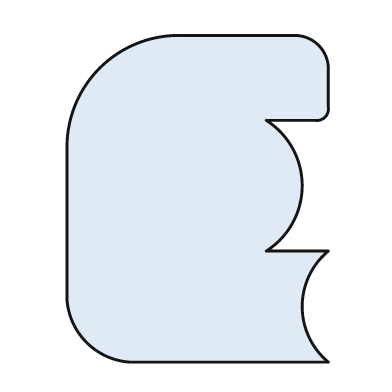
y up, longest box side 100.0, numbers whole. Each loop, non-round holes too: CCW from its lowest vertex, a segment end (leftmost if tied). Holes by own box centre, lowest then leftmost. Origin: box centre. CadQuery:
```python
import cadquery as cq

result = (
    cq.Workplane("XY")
    .moveTo(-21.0, -50.0)
    .lineTo(40.0, -50.0)
    .threePointArc((32.0, -33.0), (40.0, -16.0))
    .lineTo(21.0, -16.0)
    .threePointArc((32.0, 4.0), (21.0, 24.0))
    .lineTo(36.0, 24.0)
    .threePointArc((39.0, 25.0), (40.0, 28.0))
    .lineTo(40.0, 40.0)
    .threePointArc((37.0, 47.0), (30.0, 50.0))
    .lineTo(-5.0, 50.0)
    .threePointArc((-30.0, 40.0), (-40.0, 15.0))
    .lineTo(-40.0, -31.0)
    .threePointArc((-34.0, -44.0), (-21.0, -50.0))
    .close()
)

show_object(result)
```